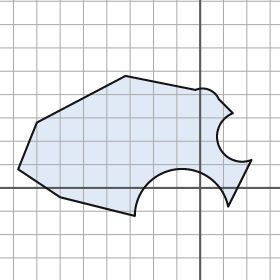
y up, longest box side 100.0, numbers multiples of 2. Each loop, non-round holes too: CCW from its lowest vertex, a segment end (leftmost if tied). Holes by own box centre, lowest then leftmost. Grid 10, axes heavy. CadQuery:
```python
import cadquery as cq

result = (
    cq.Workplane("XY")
    .moveTo(-28.0, -12.0)
    .threePointArc((-10.0, 8.0), (12.0, -8.0))
    .lineTo(22.0, 12.0)
    .threePointArc((8.0, 18.0), (14.0, 32.0))
    .lineTo(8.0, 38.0)
    .threePointArc((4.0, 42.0), (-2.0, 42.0))
    .lineTo(-32.0, 48.0)
    .lineTo(-70.0, 28.0)
    .lineTo(-78.0, 8.0)
    .lineTo(-60.0, -4.0)
    .close()
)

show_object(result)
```